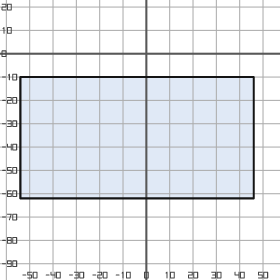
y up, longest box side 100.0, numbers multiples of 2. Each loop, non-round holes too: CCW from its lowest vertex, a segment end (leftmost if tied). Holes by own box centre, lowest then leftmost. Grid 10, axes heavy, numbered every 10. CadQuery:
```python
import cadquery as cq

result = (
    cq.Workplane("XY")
    .moveTo(-54.0, -62.0)
    .lineTo(46.0, -62.0)
    .lineTo(46.0, -10.0)
    .lineTo(-54.0, -10.0)
    .close()
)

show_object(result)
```